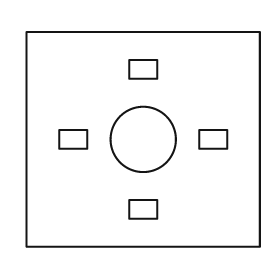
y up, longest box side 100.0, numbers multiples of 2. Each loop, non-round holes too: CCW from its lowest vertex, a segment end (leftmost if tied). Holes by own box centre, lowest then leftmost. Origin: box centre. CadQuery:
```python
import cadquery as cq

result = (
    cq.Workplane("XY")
    .moveTo(-50.0, -46.0)
    .lineTo(50.0, -46.0)
    .lineTo(50.0, 46.0)
    .lineTo(-50.0, 46.0)
    .close()
    .moveTo(-6.0, -34.0)
    .lineTo(6.0, -34.0)
    .lineTo(6.0, -26.0)
    .lineTo(-6.0, -26.0)
    .close()
    .moveTo(-36.0, -4.0)
    .lineTo(-24.0, -4.0)
    .lineTo(-24.0, 4.0)
    .lineTo(-36.0, 4.0)
    .close()
    .moveTo(0.0, 0.0)
    .circle(14.0)
    .moveTo(24.0, -4.0)
    .lineTo(36.0, -4.0)
    .lineTo(36.0, 4.0)
    .lineTo(24.0, 4.0)
    .close()
    .moveTo(-6.0, 26.0)
    .lineTo(6.0, 26.0)
    .lineTo(6.0, 34.0)
    .lineTo(-6.0, 34.0)
    .close()
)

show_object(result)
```